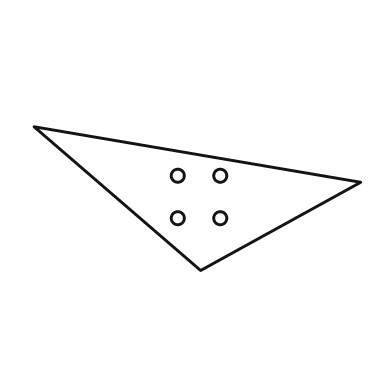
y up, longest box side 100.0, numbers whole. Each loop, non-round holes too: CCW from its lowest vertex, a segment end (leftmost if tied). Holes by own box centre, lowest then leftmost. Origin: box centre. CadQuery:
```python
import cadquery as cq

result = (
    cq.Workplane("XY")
    .moveTo(1.0, -22.0)
    .lineTo(50.0, 5.0)
    .lineTo(-50.0, 22.0)
    .close()
    .moveTo(-6.0, -6.0)
    .circle(2.0)
    .moveTo(7.0, -6.0)
    .circle(2.0)
    .moveTo(-6.0, 7.0)
    .circle(2.0)
    .moveTo(7.0, 7.0)
    .circle(2.0)
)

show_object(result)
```